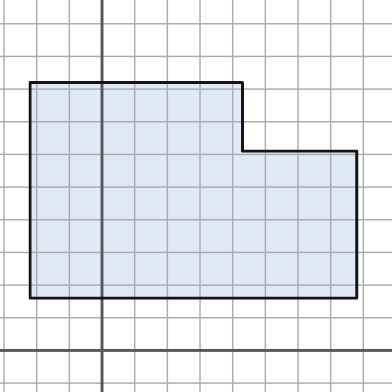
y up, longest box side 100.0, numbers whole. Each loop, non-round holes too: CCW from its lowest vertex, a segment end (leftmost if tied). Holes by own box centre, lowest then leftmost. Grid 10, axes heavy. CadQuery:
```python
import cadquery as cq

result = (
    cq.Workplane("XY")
    .moveTo(-22.0, 16.0)
    .lineTo(78.0, 16.0)
    .lineTo(78.0, 61.0)
    .lineTo(43.0, 61.0)
    .lineTo(43.0, 82.0)
    .lineTo(-22.0, 82.0)
    .close()
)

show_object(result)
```